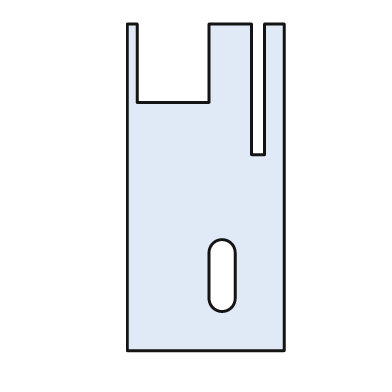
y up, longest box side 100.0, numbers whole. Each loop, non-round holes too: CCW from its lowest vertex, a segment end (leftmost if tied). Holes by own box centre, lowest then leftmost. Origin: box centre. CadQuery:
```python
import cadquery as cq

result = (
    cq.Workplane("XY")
    .moveTo(-24.0, -50.0)
    .lineTo(24.0, -50.0)
    .lineTo(24.0, 50.0)
    .lineTo(18.0, 50.0)
    .lineTo(18.0, 10.0)
    .lineTo(14.0, 10.0)
    .lineTo(14.0, 50.0)
    .lineTo(1.0, 50.0)
    .lineTo(1.0, 26.0)
    .lineTo(-21.0, 26.0)
    .lineTo(-21.0, 50.0)
    .lineTo(-24.0, 50.0)
    .close()
    .moveTo(1.0, -34.0)
    .threePointArc((5.0, -38.0), (9.0, -34.0))
    .lineTo(9.0, -20.0)
    .threePointArc((5.0, -16.0), (1.0, -20.0))
    .close()
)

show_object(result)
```